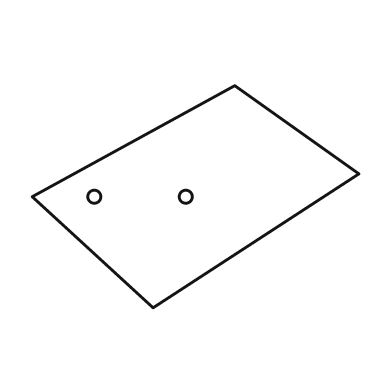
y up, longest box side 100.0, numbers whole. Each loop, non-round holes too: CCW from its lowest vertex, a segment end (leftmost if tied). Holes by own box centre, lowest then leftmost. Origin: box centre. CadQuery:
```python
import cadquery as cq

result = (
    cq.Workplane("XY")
    .moveTo(-13.0, -34.0)
    .lineTo(50.0, 7.0)
    .lineTo(12.0, 34.0)
    .lineTo(-50.0, 0.0)
    .close()
    .moveTo(-31.0, 0.0)
    .circle(2.0)
    .moveTo(-3.0, 0.0)
    .circle(2.0)
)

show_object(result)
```